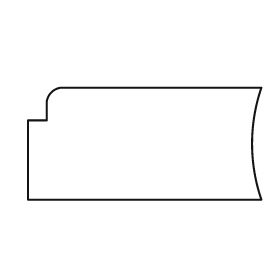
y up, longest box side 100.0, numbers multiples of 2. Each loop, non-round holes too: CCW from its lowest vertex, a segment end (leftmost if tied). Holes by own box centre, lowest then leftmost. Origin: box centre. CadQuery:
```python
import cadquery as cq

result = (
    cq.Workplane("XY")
    .moveTo(-50.0, -24.0)
    .lineTo(50.0, -24.0)
    .threePointArc((46.0, 0.0), (50.0, 24.0))
    .lineTo(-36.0, 24.0)
    .threePointArc((-40.0, 22.0), (-42.0, 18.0))
    .lineTo(-42.0, 10.0)
    .lineTo(-50.0, 10.0)
    .close()
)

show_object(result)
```